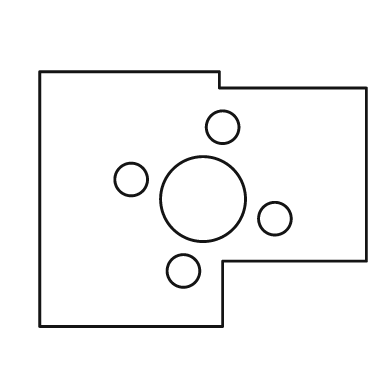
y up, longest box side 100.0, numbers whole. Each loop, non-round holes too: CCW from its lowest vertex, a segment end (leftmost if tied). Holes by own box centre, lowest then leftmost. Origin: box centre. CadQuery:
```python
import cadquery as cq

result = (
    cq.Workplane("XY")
    .moveTo(-50.0, -39.0)
    .lineTo(6.0, -39.0)
    .lineTo(6.0, -19.0)
    .lineTo(50.0, -19.0)
    .lineTo(50.0, 34.0)
    .lineTo(5.0, 34.0)
    .lineTo(5.0, 39.0)
    .lineTo(-50.0, 39.0)
    .close()
    .moveTo(-6.0, -22.0)
    .circle(5.0)
    .moveTo(22.0, -6.0)
    .circle(5.0)
    .moveTo(0.0, 0.0)
    .circle(13.0)
    .moveTo(-22.0, 6.0)
    .circle(5.0)
    .moveTo(6.0, 22.0)
    .circle(5.0)
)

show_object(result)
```